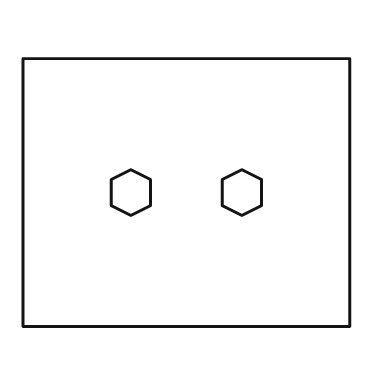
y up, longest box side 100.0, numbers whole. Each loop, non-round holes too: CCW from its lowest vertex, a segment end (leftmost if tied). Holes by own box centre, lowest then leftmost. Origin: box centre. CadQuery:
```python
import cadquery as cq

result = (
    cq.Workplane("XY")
    .moveTo(-50.0, -41.0)
    .lineTo(50.0, -41.0)
    .lineTo(50.0, 41.0)
    .lineTo(-50.0, 41.0)
    .close()
    .moveTo(-17.0, -7.0)
    .lineTo(-11.0, -4.0)
    .lineTo(-11.0, 4.0)
    .lineTo(-17.0, 7.0)
    .lineTo(-23.0, 4.0)
    .lineTo(-23.0, -4.0)
    .close()
    .moveTo(17.0, -7.0)
    .lineTo(23.0, -4.0)
    .lineTo(23.0, 4.0)
    .lineTo(17.0, 7.0)
    .lineTo(11.0, 4.0)
    .lineTo(11.0, -4.0)
    .close()
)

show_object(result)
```